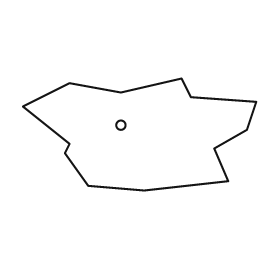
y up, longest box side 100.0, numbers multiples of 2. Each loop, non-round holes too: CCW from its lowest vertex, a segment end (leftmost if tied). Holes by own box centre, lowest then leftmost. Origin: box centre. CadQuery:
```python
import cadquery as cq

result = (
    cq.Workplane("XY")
    .moveTo(2.0, -24.0)
    .lineTo(38.0, -20.0)
    .lineTo(32.0, -6.0)
    .lineTo(46.0, 2.0)
    .lineTo(50.0, 14.0)
    .lineTo(22.0, 16.0)
    .lineTo(18.0, 24.0)
    .lineTo(-8.0, 18.0)
    .lineTo(-30.0, 22.0)
    .lineTo(-50.0, 12.0)
    .lineTo(-30.0, -4.0)
    .lineTo(-32.0, -8.0)
    .lineTo(-22.0, -22.0)
    .close()
    .moveTo(-8.0, 4.0)
    .circle(2.0)
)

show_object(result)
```